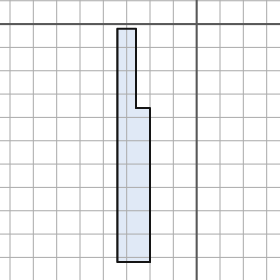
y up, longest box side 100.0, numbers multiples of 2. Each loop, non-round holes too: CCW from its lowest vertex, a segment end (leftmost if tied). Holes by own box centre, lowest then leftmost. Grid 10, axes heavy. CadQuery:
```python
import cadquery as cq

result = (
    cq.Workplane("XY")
    .moveTo(-34.0, -102.0)
    .lineTo(-20.0, -102.0)
    .lineTo(-20.0, -36.0)
    .lineTo(-26.0, -36.0)
    .lineTo(-26.0, -2.0)
    .lineTo(-34.0, -2.0)
    .close()
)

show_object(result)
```